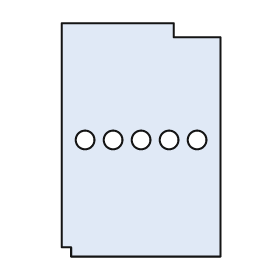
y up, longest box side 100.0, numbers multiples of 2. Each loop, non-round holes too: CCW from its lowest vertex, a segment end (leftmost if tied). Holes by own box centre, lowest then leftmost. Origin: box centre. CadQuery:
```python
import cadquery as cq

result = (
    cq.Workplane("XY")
    .moveTo(-30.0, -50.0)
    .lineTo(34.0, -50.0)
    .lineTo(34.0, 44.0)
    .lineTo(14.0, 44.0)
    .lineTo(14.0, 50.0)
    .lineTo(-34.0, 50.0)
    .lineTo(-34.0, -46.0)
    .lineTo(-30.0, -46.0)
    .close()
    .moveTo(-24.0, 0.0)
    .circle(4.0)
    .moveTo(-12.0, 0.0)
    .circle(4.0)
    .moveTo(0.0, 0.0)
    .circle(4.0)
    .moveTo(12.0, 0.0)
    .circle(4.0)
    .moveTo(24.0, 0.0)
    .circle(4.0)
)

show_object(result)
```